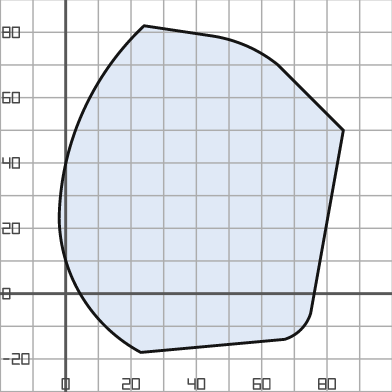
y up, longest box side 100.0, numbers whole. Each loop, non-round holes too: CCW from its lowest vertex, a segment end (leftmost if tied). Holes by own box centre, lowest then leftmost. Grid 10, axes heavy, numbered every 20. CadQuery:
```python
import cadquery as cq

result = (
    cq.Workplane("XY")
    .moveTo(23.0, -18.0)
    .lineTo(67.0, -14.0)
    .threePointArc((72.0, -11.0), (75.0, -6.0))
    .lineTo(85.0, 50.0)
    .lineTo(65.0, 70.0)
    .threePointArc((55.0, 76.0), (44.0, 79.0))
    .lineTo(24.0, 82.0)
    .threePointArc((5.0, 55.0), (-2.0, 23.0))
    .threePointArc((5.0, -1.0), (23.0, -18.0))
    .close()
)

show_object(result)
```